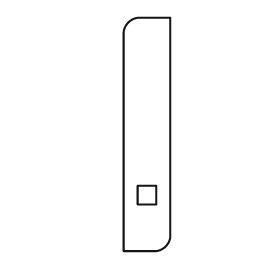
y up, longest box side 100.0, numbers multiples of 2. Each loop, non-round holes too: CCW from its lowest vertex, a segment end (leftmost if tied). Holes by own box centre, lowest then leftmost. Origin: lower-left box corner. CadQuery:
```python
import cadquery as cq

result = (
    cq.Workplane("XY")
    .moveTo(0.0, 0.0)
    .lineTo(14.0, 0.0)
    .threePointArc((18.0, 2.0), (20.0, 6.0))
    .lineTo(20.0, 100.0)
    .lineTo(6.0, 100.0)
    .threePointArc((2.0, 98.0), (0.0, 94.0))
    .close()
    .moveTo(6.0, 20.0)
    .lineTo(14.0, 20.0)
    .lineTo(14.0, 28.0)
    .lineTo(6.0, 28.0)
    .close()
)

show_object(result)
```